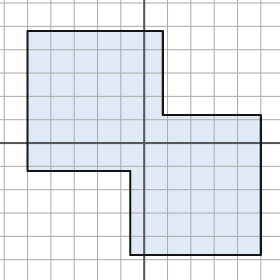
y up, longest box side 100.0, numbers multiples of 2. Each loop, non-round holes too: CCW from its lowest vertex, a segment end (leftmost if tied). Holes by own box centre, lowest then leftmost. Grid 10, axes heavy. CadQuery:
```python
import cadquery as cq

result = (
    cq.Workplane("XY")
    .moveTo(-6.0, -48.0)
    .lineTo(50.0, -48.0)
    .lineTo(50.0, 12.0)
    .lineTo(8.0, 12.0)
    .lineTo(8.0, 48.0)
    .lineTo(-50.0, 48.0)
    .lineTo(-50.0, -12.0)
    .lineTo(-6.0, -12.0)
    .close()
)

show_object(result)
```